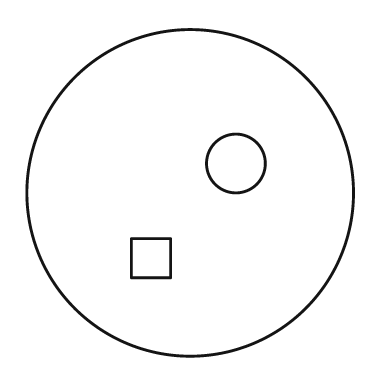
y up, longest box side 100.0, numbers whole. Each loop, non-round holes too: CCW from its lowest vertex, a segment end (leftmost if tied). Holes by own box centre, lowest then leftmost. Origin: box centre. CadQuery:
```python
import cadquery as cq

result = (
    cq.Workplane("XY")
    .moveTo(0.0, 0.0)
    .circle(50.0)
    .moveTo(-18.0, -26.0)
    .lineTo(-6.0, -26.0)
    .lineTo(-6.0, -14.0)
    .lineTo(-18.0, -14.0)
    .close()
    .moveTo(14.0, 9.0)
    .circle(9.0)
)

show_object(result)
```